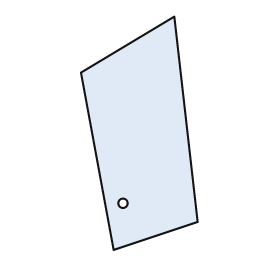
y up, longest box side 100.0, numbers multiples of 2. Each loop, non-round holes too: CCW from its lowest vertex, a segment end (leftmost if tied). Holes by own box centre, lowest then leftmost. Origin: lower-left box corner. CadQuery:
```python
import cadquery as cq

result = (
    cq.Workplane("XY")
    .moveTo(14.0, 0.0)
    .lineTo(50.0, 12.0)
    .lineTo(40.0, 100.0)
    .lineTo(0.0, 76.0)
    .close()
    .moveTo(18.0, 20.0)
    .circle(2.0)
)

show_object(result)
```